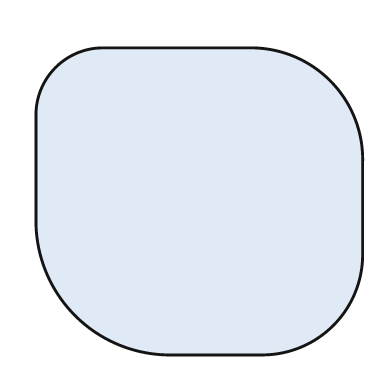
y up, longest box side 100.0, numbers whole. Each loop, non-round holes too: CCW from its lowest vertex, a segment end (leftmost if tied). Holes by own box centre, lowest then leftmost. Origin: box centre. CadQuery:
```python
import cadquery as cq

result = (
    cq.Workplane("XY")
    .moveTo(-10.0, -47.0)
    .lineTo(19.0, -47.0)
    .threePointArc((41.0, -38.0), (50.0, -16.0))
    .lineTo(50.0, 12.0)
    .threePointArc((40.0, 37.0), (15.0, 47.0))
    .lineTo(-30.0, 47.0)
    .threePointArc((-44.0, 41.0), (-50.0, 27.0))
    .lineTo(-50.0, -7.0)
    .threePointArc((-38.0, -35.0), (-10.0, -47.0))
    .close()
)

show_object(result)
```